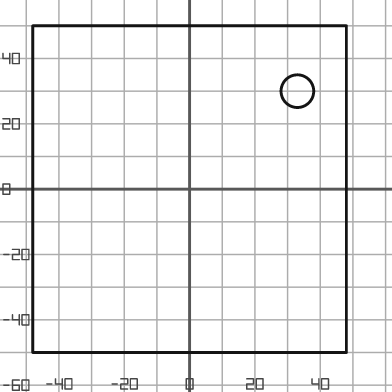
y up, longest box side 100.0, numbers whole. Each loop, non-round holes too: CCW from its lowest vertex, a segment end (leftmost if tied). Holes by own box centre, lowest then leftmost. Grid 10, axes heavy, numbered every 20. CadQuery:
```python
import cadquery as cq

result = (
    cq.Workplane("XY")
    .moveTo(-48.0, -50.0)
    .lineTo(48.0, -50.0)
    .lineTo(48.0, 50.0)
    .lineTo(-48.0, 50.0)
    .close()
    .moveTo(33.0, 30.0)
    .circle(5.0)
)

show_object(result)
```